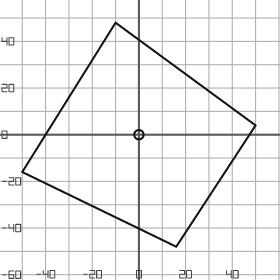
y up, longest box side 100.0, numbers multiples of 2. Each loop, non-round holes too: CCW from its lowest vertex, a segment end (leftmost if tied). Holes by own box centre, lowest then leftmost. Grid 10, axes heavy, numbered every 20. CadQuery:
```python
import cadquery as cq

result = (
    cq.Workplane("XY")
    .moveTo(16.0, -48.0)
    .lineTo(50.0, 4.0)
    .lineTo(-10.0, 48.0)
    .lineTo(-50.0, -16.0)
    .close()
    .moveTo(0.0, 0.0)
    .circle(2.0)
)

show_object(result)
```